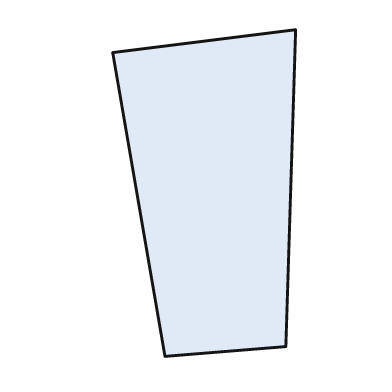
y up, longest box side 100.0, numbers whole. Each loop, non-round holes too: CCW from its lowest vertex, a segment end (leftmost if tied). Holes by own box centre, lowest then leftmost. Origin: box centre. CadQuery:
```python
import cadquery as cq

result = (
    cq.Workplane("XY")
    .moveTo(-12.0, -50.0)
    .lineTo(25.0, -47.0)
    .lineTo(28.0, 50.0)
    .lineTo(-28.0, 43.0)
    .close()
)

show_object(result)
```